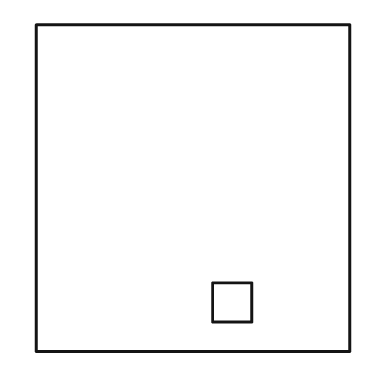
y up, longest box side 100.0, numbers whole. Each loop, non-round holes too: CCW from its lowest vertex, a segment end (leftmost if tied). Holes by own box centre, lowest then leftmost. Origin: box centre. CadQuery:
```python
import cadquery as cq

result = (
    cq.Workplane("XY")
    .moveTo(-48.0, -50.0)
    .lineTo(48.0, -50.0)
    .lineTo(48.0, 50.0)
    .lineTo(-48.0, 50.0)
    .close()
    .moveTo(6.0, -41.0)
    .lineTo(18.0, -41.0)
    .lineTo(18.0, -29.0)
    .lineTo(6.0, -29.0)
    .close()
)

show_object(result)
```